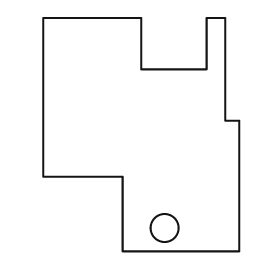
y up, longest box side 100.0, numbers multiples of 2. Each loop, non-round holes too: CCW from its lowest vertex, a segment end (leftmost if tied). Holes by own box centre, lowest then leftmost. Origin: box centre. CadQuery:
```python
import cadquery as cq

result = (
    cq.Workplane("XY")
    .moveTo(-8.0, -50.0)
    .lineTo(42.0, -50.0)
    .lineTo(42.0, 6.0)
    .lineTo(36.0, 6.0)
    .lineTo(36.0, 50.0)
    .lineTo(28.0, 50.0)
    .lineTo(28.0, 28.0)
    .lineTo(0.0, 28.0)
    .lineTo(0.0, 50.0)
    .lineTo(-42.0, 50.0)
    .lineTo(-42.0, -18.0)
    .lineTo(-8.0, -18.0)
    .close()
    .moveTo(10.0, -40.0)
    .circle(6.0)
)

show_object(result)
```